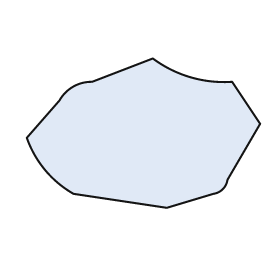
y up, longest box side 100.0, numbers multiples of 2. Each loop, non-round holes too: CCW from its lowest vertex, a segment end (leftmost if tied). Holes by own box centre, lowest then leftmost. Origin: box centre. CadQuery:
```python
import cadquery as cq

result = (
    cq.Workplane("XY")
    .moveTo(10.0, -32.0)
    .lineTo(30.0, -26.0)
    .threePointArc((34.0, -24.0), (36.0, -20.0))
    .lineTo(50.0, 4.0)
    .lineTo(38.0, 22.0)
    .threePointArc((20.0, 24.0), (4.0, 32.0))
    .lineTo(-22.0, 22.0)
    .threePointArc((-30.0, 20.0), (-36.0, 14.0))
    .lineTo(-50.0, -2.0)
    .threePointArc((-42.0, -16.0), (-30.0, -26.0))
    .close()
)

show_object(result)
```